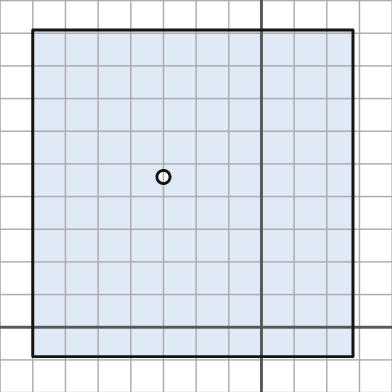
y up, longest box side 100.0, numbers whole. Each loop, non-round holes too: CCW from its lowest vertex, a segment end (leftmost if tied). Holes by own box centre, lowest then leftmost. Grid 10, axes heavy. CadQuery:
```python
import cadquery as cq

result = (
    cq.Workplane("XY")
    .moveTo(-70.0, -9.0)
    .lineTo(28.0, -9.0)
    .lineTo(28.0, 91.0)
    .lineTo(-70.0, 91.0)
    .close()
    .moveTo(-30.0, 46.0)
    .circle(2.0)
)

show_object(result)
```